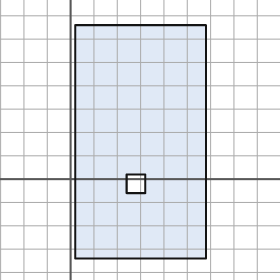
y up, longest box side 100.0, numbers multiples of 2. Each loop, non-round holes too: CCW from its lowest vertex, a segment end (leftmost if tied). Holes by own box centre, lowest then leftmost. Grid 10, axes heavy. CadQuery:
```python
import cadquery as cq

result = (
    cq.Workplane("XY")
    .moveTo(2.0, -34.0)
    .lineTo(58.0, -34.0)
    .lineTo(58.0, 66.0)
    .lineTo(2.0, 66.0)
    .close()
    .moveTo(24.0, -6.0)
    .lineTo(32.0, -6.0)
    .lineTo(32.0, 2.0)
    .lineTo(24.0, 2.0)
    .close()
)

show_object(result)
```